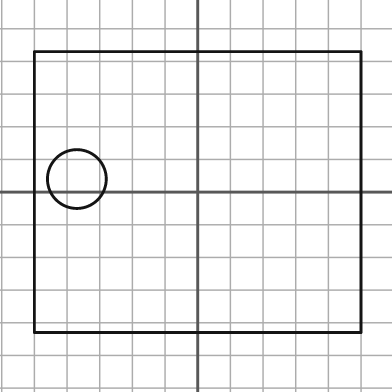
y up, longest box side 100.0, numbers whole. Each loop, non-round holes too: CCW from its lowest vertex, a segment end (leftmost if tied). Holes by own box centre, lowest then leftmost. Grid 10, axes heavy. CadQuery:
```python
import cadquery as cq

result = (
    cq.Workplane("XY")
    .moveTo(-50.0, -43.0)
    .lineTo(50.0, -43.0)
    .lineTo(50.0, 43.0)
    .lineTo(-50.0, 43.0)
    .close()
    .moveTo(-37.0, 4.0)
    .circle(9.0)
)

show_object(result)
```